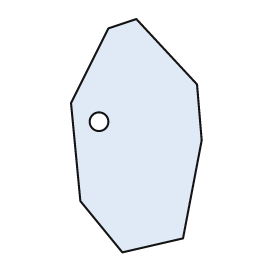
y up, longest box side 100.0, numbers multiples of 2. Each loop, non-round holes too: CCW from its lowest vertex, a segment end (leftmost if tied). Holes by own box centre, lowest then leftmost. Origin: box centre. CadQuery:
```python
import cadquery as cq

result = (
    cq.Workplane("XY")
    .moveTo(-6.0, -50.0)
    .lineTo(20.0, -44.0)
    .lineTo(28.0, -2.0)
    .lineTo(26.0, 22.0)
    .lineTo(0.0, 50.0)
    .lineTo(-12.0, 46.0)
    .lineTo(-28.0, 14.0)
    .lineTo(-24.0, -28.0)
    .close()
    .moveTo(-16.0, 6.0)
    .circle(4.0)
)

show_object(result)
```